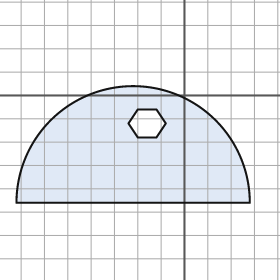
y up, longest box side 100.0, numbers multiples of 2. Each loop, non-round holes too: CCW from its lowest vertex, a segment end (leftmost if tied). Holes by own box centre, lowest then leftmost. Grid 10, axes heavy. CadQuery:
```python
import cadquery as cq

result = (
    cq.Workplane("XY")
    .moveTo(-72.0, -46.0)
    .lineTo(28.0, -46.0)
    .threePointArc((-22.0, 4.0), (-72.0, -46.0))
    .close()
    .moveTo(-20.0, -18.0)
    .lineTo(-12.0, -18.0)
    .lineTo(-8.0, -12.0)
    .lineTo(-12.0, -6.0)
    .lineTo(-20.0, -6.0)
    .lineTo(-24.0, -12.0)
    .close()
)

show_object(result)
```